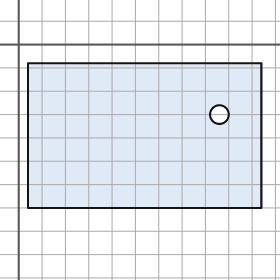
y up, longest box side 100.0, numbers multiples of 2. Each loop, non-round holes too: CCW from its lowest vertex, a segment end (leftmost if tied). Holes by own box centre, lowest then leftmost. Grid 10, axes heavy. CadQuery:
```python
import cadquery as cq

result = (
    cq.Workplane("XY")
    .moveTo(4.0, -70.0)
    .lineTo(104.0, -70.0)
    .lineTo(104.0, -8.0)
    .lineTo(4.0, -8.0)
    .close()
    .moveTo(86.0, -30.0)
    .circle(4.0)
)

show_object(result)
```